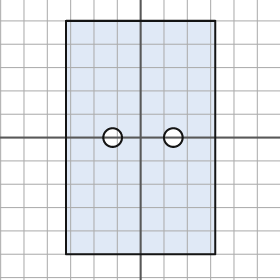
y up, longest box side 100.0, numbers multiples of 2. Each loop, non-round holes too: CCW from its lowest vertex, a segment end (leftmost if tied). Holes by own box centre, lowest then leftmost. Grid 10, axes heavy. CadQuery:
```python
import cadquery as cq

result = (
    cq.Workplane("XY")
    .moveTo(-32.0, -50.0)
    .lineTo(32.0, -50.0)
    .lineTo(32.0, 50.0)
    .lineTo(-32.0, 50.0)
    .close()
    .moveTo(-12.0, 0.0)
    .circle(4.0)
    .moveTo(14.0, 0.0)
    .circle(4.0)
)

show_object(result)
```